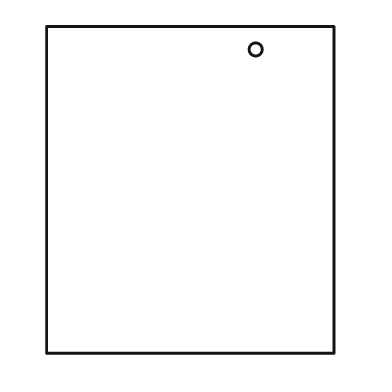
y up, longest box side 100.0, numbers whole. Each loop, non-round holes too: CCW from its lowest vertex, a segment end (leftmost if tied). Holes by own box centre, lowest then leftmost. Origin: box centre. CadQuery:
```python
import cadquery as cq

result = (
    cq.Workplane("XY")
    .moveTo(-44.0, -50.0)
    .lineTo(44.0, -50.0)
    .lineTo(44.0, 50.0)
    .lineTo(-44.0, 50.0)
    .close()
    .moveTo(20.0, 43.0)
    .circle(2.0)
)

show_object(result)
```